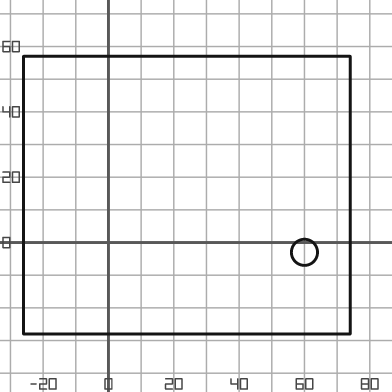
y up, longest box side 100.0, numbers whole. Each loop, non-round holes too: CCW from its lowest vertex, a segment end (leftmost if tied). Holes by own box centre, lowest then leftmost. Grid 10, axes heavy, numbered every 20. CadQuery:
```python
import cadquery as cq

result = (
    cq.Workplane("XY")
    .moveTo(-26.0, -28.0)
    .lineTo(74.0, -28.0)
    .lineTo(74.0, 57.0)
    .lineTo(-26.0, 57.0)
    .close()
    .moveTo(60.0, -3.0)
    .circle(4.0)
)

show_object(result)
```